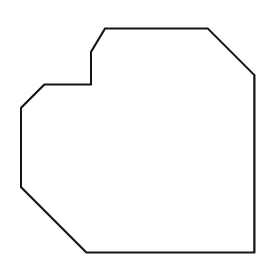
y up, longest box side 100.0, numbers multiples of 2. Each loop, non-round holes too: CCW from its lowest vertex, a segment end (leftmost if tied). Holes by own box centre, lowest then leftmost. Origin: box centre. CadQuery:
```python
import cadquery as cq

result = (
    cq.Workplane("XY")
    .moveTo(-22.0, -48.0)
    .lineTo(50.0, -48.0)
    .lineTo(50.0, 28.0)
    .lineTo(30.0, 48.0)
    .lineTo(-14.0, 48.0)
    .lineTo(-20.0, 38.0)
    .lineTo(-20.0, 24.0)
    .lineTo(-40.0, 24.0)
    .lineTo(-50.0, 14.0)
    .lineTo(-50.0, -20.0)
    .close()
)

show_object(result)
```